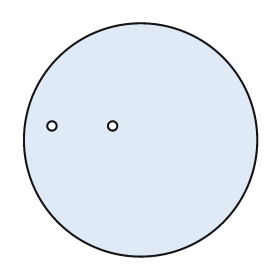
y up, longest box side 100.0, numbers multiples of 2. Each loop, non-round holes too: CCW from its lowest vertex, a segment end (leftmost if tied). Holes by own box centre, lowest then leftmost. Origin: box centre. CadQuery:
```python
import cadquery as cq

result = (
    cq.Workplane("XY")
    .moveTo(0.0, 0.0)
    .circle(50.0)
    .moveTo(-38.0, 6.0)
    .circle(2.0)
    .moveTo(-12.0, 6.0)
    .circle(2.0)
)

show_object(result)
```